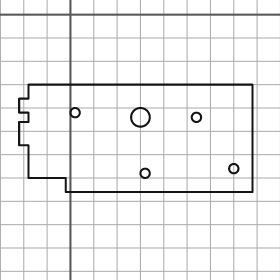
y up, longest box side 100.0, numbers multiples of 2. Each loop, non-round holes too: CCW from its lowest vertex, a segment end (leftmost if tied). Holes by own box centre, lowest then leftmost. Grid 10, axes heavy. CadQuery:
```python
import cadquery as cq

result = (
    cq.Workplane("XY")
    .moveTo(-2.0, -76.0)
    .lineTo(78.0, -76.0)
    .lineTo(78.0, -30.0)
    .lineTo(-18.0, -30.0)
    .lineTo(-18.0, -36.0)
    .lineTo(-22.0, -36.0)
    .lineTo(-22.0, -42.0)
    .lineTo(-18.0, -42.0)
    .lineTo(-18.0, -46.0)
    .lineTo(-22.0, -46.0)
    .lineTo(-22.0, -56.0)
    .lineTo(-18.0, -56.0)
    .lineTo(-18.0, -70.0)
    .lineTo(-2.0, -70.0)
    .close()
    .moveTo(32.0, -68.0)
    .circle(2.0)
    .moveTo(70.0, -66.0)
    .circle(2.0)
    .moveTo(30.0, -44.0)
    .circle(4.0)
    .moveTo(54.0, -44.0)
    .circle(2.0)
    .moveTo(2.0, -42.0)
    .circle(2.0)
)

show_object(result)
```